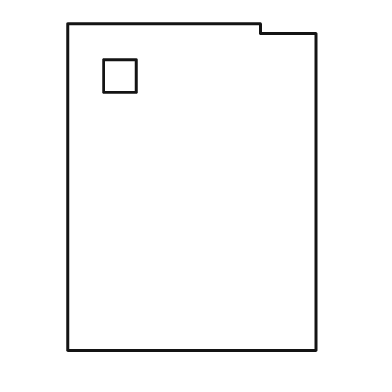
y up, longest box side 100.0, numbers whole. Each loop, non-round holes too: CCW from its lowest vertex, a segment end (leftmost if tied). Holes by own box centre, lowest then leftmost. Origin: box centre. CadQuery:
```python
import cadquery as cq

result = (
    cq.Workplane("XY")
    .moveTo(-38.0, -50.0)
    .lineTo(38.0, -50.0)
    .lineTo(38.0, 47.0)
    .lineTo(21.0, 47.0)
    .lineTo(21.0, 50.0)
    .lineTo(-38.0, 50.0)
    .close()
    .moveTo(-27.0, 29.0)
    .lineTo(-17.0, 29.0)
    .lineTo(-17.0, 39.0)
    .lineTo(-27.0, 39.0)
    .close()
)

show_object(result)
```